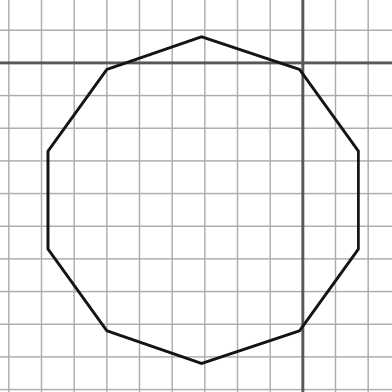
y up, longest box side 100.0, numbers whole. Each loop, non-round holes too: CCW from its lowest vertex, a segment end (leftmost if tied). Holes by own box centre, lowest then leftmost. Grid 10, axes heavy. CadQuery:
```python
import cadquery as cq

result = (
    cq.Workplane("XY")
    .moveTo(-31.0, -92.0)
    .lineTo(-1.0, -82.0)
    .lineTo(17.0, -57.0)
    .lineTo(17.0, -27.0)
    .lineTo(-1.0, -2.0)
    .lineTo(-31.0, 8.0)
    .lineTo(-60.0, -2.0)
    .lineTo(-78.0, -27.0)
    .lineTo(-78.0, -57.0)
    .lineTo(-60.0, -82.0)
    .close()
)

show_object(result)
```